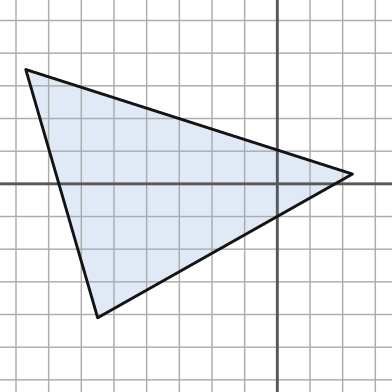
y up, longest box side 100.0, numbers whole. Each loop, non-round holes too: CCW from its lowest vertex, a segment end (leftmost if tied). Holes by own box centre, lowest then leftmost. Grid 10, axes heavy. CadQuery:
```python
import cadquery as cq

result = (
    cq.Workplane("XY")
    .moveTo(-55.0, -41.0)
    .lineTo(23.0, 3.0)
    .lineTo(-77.0, 35.0)
    .close()
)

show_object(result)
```